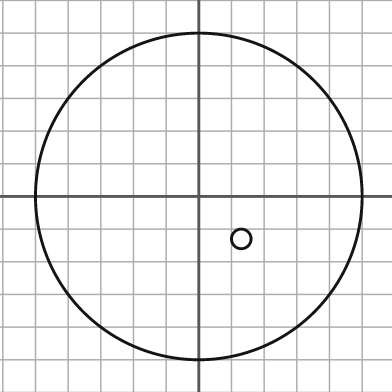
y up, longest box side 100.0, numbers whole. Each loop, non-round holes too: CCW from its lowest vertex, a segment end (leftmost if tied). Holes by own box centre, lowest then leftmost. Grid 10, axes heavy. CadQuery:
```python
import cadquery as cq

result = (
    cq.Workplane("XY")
    .moveTo(0.0, 0.0)
    .circle(50.0)
    .moveTo(13.0, -13.0)
    .circle(3.0)
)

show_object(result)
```